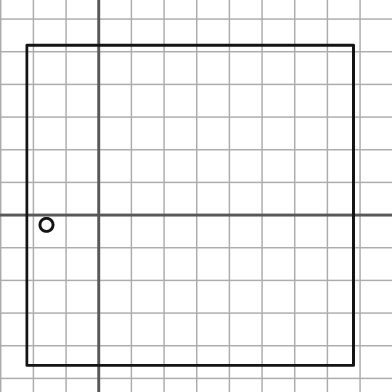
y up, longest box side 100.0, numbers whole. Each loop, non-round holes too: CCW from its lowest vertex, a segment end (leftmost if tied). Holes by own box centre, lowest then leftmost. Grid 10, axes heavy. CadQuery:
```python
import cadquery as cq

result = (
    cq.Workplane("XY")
    .moveTo(-22.0, -46.0)
    .lineTo(78.0, -46.0)
    .lineTo(78.0, 52.0)
    .lineTo(-22.0, 52.0)
    .close()
    .moveTo(-16.0, -3.0)
    .circle(2.0)
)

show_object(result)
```